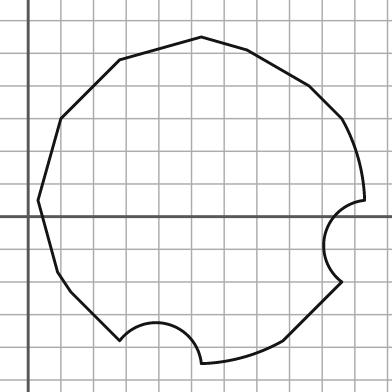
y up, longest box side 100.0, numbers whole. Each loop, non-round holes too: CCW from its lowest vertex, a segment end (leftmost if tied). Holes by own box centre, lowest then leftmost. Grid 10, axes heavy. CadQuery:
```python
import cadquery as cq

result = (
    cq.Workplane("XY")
    .moveTo(53.0, -45.0)
    .threePointArc((66.0, -43.0), (78.0, -38.0))
    .lineTo(96.0, -20.0)
    .threePointArc((91.0, -5.0), (103.0, 5.0))
    .threePointArc((101.0, 18.0), (96.0, 30.0))
    .lineTo(86.0, 40.0)
    .lineTo(67.0, 51.0)
    .lineTo(53.0, 55.0)
    .lineTo(28.0, 48.0)
    .lineTo(10.0, 30.0)
    .lineTo(3.0, 5.0)
    .lineTo(9.0, -17.0)
    .lineTo(13.0, -23.0)
    .lineTo(28.0, -38.0)
    .threePointArc((43.0, -33.0), (53.0, -45.0))
    .close()
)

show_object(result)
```